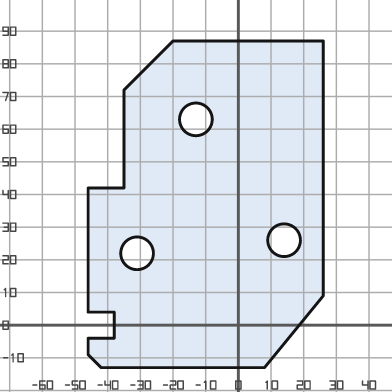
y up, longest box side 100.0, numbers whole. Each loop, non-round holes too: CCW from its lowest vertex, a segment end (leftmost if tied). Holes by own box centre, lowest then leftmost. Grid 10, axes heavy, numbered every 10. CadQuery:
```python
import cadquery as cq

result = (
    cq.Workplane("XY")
    .moveTo(-42.0, -13.0)
    .lineTo(8.0, -13.0)
    .lineTo(26.0, 9.0)
    .lineTo(26.0, 87.0)
    .lineTo(-20.0, 87.0)
    .lineTo(-35.0, 72.0)
    .lineTo(-35.0, 42.0)
    .lineTo(-46.0, 42.0)
    .lineTo(-46.0, 4.0)
    .lineTo(-38.0, 4.0)
    .lineTo(-38.0, -4.0)
    .lineTo(-46.0, -4.0)
    .lineTo(-46.0, -9.0)
    .close()
    .moveTo(-31.0, 22.0)
    .circle(5.0)
    .moveTo(14.0, 26.0)
    .circle(5.0)
    .moveTo(-13.0, 63.0)
    .circle(5.0)
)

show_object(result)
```